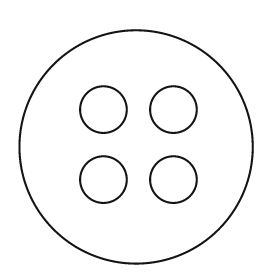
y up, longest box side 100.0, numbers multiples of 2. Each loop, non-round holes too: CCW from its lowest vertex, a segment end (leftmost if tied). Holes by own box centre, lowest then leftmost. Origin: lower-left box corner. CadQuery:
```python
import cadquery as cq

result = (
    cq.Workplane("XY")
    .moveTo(50.0, 50.0)
    .circle(50.0)
    .moveTo(36.0, 36.0)
    .circle(10.0)
    .moveTo(66.0, 36.0)
    .circle(10.0)
    .moveTo(36.0, 66.0)
    .circle(10.0)
    .moveTo(66.0, 66.0)
    .circle(10.0)
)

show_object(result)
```